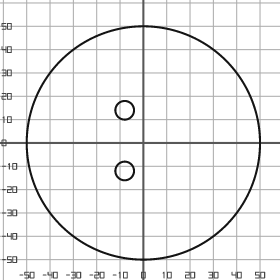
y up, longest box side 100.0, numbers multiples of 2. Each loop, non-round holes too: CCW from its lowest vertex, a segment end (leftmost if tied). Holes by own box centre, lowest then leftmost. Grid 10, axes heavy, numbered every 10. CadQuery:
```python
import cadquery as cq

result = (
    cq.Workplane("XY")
    .moveTo(0.0, 0.0)
    .circle(50.0)
    .moveTo(-8.0, -12.0)
    .circle(4.0)
    .moveTo(-8.0, 14.0)
    .circle(4.0)
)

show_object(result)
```